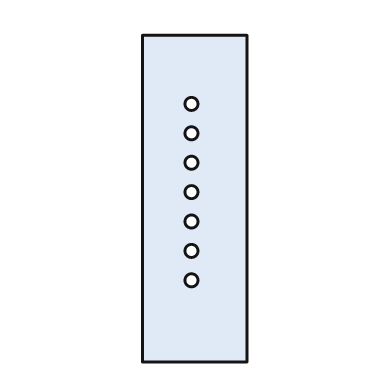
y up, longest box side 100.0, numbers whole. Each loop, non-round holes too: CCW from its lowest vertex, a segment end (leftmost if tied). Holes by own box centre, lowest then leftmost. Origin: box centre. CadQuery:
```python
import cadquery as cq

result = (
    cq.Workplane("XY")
    .moveTo(-16.0, -50.0)
    .lineTo(16.0, -50.0)
    .lineTo(16.0, 50.0)
    .lineTo(-16.0, 50.0)
    .close()
    .moveTo(-1.0, -25.0)
    .circle(2.0)
    .moveTo(-1.0, -16.0)
    .circle(2.0)
    .moveTo(-1.0, -7.0)
    .circle(2.0)
    .moveTo(-1.0, 2.0)
    .circle(2.0)
    .moveTo(-1.0, 11.0)
    .circle(2.0)
    .moveTo(-1.0, 20.0)
    .circle(2.0)
    .moveTo(-1.0, 29.0)
    .circle(2.0)
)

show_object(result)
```